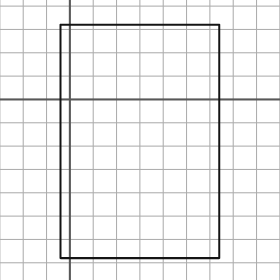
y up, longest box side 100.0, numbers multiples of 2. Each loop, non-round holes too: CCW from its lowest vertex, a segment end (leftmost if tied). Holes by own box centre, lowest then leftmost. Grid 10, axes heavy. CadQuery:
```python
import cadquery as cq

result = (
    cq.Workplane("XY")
    .moveTo(-4.0, -68.0)
    .lineTo(64.0, -68.0)
    .lineTo(64.0, 32.0)
    .lineTo(-4.0, 32.0)
    .close()
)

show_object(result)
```